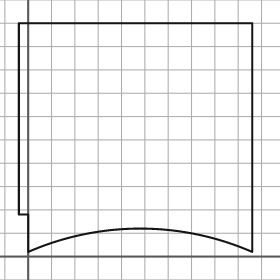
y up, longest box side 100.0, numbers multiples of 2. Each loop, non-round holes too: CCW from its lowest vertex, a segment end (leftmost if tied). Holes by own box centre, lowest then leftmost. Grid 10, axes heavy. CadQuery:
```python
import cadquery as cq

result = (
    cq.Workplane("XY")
    .moveTo(0.0, 2.0)
    .threePointArc((48.0, 12.0), (96.0, 2.0))
    .lineTo(96.0, 100.0)
    .lineTo(-4.0, 100.0)
    .lineTo(-4.0, 18.0)
    .lineTo(0.0, 18.0)
    .close()
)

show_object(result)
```